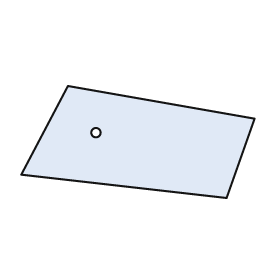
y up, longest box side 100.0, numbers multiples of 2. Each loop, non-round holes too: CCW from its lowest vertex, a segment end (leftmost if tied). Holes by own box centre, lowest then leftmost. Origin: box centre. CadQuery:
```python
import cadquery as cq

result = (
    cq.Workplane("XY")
    .moveTo(38.0, -24.0)
    .lineTo(50.0, 10.0)
    .lineTo(-30.0, 24.0)
    .lineTo(-50.0, -14.0)
    .close()
    .moveTo(-18.0, 4.0)
    .circle(2.0)
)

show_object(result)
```